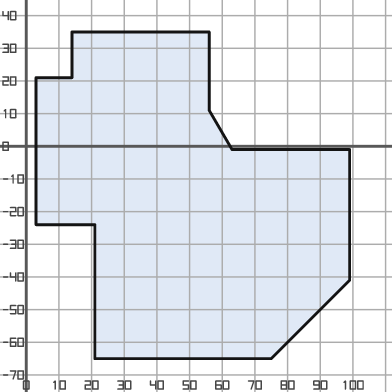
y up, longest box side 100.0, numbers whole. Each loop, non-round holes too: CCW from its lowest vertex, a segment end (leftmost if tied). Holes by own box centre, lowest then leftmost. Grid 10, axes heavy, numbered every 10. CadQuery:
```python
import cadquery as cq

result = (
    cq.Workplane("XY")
    .moveTo(21.0, -65.0)
    .lineTo(75.0, -65.0)
    .lineTo(99.0, -41.0)
    .lineTo(99.0, -1.0)
    .lineTo(63.0, -1.0)
    .lineTo(56.0, 11.0)
    .lineTo(56.0, 35.0)
    .lineTo(14.0, 35.0)
    .lineTo(14.0, 21.0)
    .lineTo(3.0, 21.0)
    .lineTo(3.0, -24.0)
    .lineTo(21.0, -24.0)
    .close()
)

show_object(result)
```